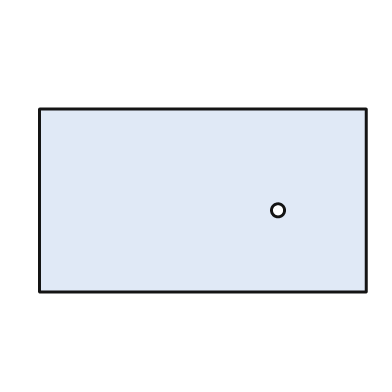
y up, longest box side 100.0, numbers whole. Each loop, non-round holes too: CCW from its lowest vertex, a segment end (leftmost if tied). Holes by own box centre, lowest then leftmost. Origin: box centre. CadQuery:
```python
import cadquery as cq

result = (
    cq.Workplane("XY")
    .moveTo(-50.0, -28.0)
    .lineTo(50.0, -28.0)
    .lineTo(50.0, 28.0)
    .lineTo(-50.0, 28.0)
    .close()
    .moveTo(23.0, -3.0)
    .circle(2.0)
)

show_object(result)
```